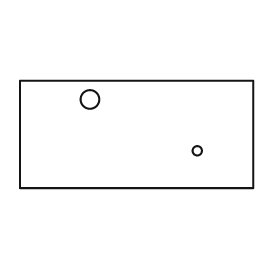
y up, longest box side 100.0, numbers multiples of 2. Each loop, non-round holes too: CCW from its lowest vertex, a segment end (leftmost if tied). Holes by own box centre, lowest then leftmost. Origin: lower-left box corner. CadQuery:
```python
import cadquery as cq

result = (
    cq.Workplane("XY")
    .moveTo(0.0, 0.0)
    .lineTo(100.0, 0.0)
    .lineTo(100.0, 46.0)
    .lineTo(0.0, 46.0)
    .close()
    .moveTo(76.0, 16.0)
    .circle(2.0)
    .moveTo(30.0, 38.0)
    .circle(4.0)
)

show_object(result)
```